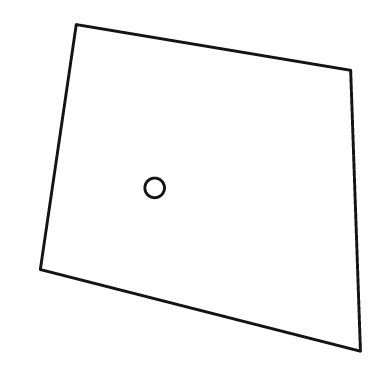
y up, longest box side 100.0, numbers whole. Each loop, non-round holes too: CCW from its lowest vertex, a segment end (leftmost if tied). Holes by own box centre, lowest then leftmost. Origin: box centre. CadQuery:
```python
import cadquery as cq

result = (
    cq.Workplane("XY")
    .moveTo(49.0, -50.0)
    .lineTo(46.0, 36.0)
    .lineTo(-38.0, 50.0)
    .lineTo(-49.0, -25.0)
    .close()
    .moveTo(-14.0, 0.0)
    .circle(3.0)
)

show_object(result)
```